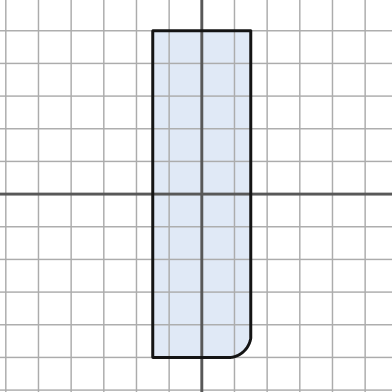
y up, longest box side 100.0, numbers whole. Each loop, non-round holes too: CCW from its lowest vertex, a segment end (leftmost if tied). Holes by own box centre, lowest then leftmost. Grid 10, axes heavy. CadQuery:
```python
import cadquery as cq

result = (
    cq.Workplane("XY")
    .moveTo(-15.0, -50.0)
    .lineTo(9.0, -50.0)
    .threePointArc((13.0, -48.0), (15.0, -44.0))
    .lineTo(15.0, 50.0)
    .lineTo(-15.0, 50.0)
    .close()
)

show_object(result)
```